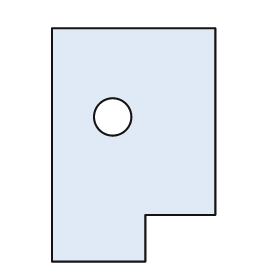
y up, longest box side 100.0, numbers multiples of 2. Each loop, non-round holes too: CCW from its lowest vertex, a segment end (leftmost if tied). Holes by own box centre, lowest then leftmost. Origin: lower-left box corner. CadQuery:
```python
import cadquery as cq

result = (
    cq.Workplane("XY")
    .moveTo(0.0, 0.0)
    .lineTo(40.0, 0.0)
    .lineTo(40.0, 20.0)
    .lineTo(70.0, 20.0)
    .lineTo(70.0, 100.0)
    .lineTo(0.0, 100.0)
    .close()
    .moveTo(26.0, 62.0)
    .circle(8.0)
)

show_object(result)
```